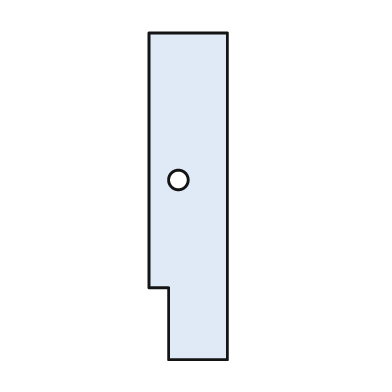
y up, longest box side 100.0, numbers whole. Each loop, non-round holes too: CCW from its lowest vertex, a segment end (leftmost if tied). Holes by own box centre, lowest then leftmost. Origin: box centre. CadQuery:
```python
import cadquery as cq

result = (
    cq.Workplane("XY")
    .moveTo(-6.0, -50.0)
    .lineTo(12.0, -50.0)
    .lineTo(12.0, 50.0)
    .lineTo(-12.0, 50.0)
    .lineTo(-12.0, -28.0)
    .lineTo(-6.0, -28.0)
    .close()
    .moveTo(-3.0, 5.0)
    .circle(3.0)
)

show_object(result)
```